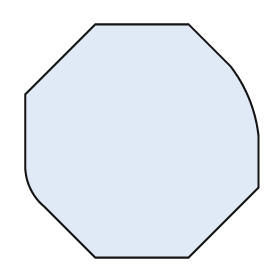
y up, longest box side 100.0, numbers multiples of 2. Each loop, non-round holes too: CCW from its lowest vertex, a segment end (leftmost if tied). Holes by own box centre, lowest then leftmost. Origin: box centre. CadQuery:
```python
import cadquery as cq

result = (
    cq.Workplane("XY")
    .moveTo(-20.0, -50.0)
    .lineTo(20.0, -50.0)
    .lineTo(50.0, -20.0)
    .lineTo(50.0, 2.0)
    .threePointArc((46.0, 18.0), (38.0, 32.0))
    .lineTo(20.0, 50.0)
    .lineTo(-20.0, 50.0)
    .lineTo(-50.0, 20.0)
    .lineTo(-50.0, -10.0)
    .threePointArc((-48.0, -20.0), (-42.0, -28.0))
    .close()
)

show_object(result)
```